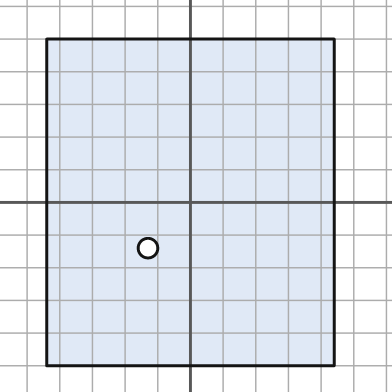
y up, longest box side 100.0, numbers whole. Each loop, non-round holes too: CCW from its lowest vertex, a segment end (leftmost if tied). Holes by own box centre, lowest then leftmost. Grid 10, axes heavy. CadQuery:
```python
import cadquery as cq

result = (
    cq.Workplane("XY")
    .moveTo(-44.0, -50.0)
    .lineTo(44.0, -50.0)
    .lineTo(44.0, 50.0)
    .lineTo(-44.0, 50.0)
    .close()
    .moveTo(-13.0, -14.0)
    .circle(3.0)
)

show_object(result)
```